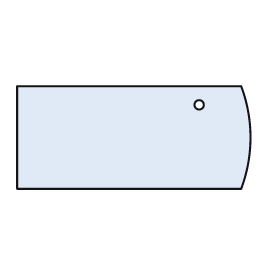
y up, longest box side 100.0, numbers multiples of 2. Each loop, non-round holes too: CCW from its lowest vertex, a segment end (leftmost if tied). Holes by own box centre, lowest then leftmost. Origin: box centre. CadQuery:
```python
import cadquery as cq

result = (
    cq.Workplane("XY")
    .moveTo(-50.0, -22.0)
    .lineTo(46.0, -22.0)
    .threePointArc((50.0, 0.0), (46.0, 22.0))
    .lineTo(-50.0, 22.0)
    .close()
    .moveTo(28.0, 14.0)
    .circle(2.0)
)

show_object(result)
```